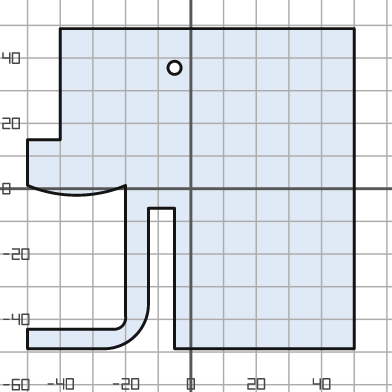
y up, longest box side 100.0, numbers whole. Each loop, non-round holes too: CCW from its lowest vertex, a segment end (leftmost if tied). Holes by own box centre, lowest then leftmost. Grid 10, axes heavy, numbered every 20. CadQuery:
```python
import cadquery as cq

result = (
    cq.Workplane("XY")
    .moveTo(-50.0, -49.0)
    .lineTo(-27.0, -49.0)
    .threePointArc((-17.0, -45.0), (-13.0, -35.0))
    .lineTo(-13.0, -6.0)
    .lineTo(-5.0, -6.0)
    .lineTo(-5.0, -49.0)
    .lineTo(50.0, -49.0)
    .lineTo(50.0, 49.0)
    .lineTo(-40.0, 49.0)
    .lineTo(-40.0, 15.0)
    .lineTo(-50.0, 15.0)
    .lineTo(-50.0, 1.0)
    .threePointArc((-35.0, -2.0), (-20.0, 1.0))
    .lineTo(-20.0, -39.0)
    .threePointArc((-21.0, -42.0), (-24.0, -43.0))
    .lineTo(-50.0, -43.0)
    .close()
    .moveTo(-5.0, 37.0)
    .circle(2.0)
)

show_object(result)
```